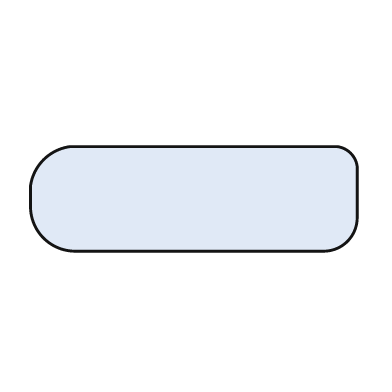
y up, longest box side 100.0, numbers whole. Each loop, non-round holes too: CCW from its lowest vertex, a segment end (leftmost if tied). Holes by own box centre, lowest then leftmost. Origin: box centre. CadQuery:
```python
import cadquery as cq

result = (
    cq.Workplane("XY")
    .moveTo(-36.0, -16.0)
    .lineTo(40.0, -16.0)
    .threePointArc((47.0, -13.0), (50.0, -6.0))
    .lineTo(50.0, 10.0)
    .threePointArc((48.0, 14.0), (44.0, 16.0))
    .lineTo(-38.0, 16.0)
    .threePointArc((-46.0, 12.0), (-50.0, 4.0))
    .lineTo(-50.0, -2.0)
    .threePointArc((-46.0, -12.0), (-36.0, -16.0))
    .close()
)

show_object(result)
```